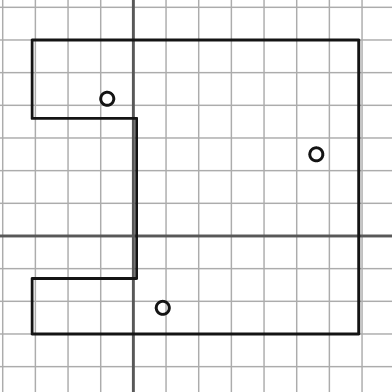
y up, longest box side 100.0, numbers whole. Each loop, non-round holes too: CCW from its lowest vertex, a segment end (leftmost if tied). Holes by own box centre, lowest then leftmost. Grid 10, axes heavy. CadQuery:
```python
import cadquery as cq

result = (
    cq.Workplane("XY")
    .moveTo(-31.0, -30.0)
    .lineTo(69.0, -30.0)
    .lineTo(69.0, 60.0)
    .lineTo(-31.0, 60.0)
    .lineTo(-31.0, 36.0)
    .lineTo(1.0, 36.0)
    .lineTo(1.0, -13.0)
    .lineTo(-31.0, -13.0)
    .close()
    .moveTo(9.0, -22.0)
    .circle(2.0)
    .moveTo(56.0, 25.0)
    .circle(2.0)
    .moveTo(-8.0, 42.0)
    .circle(2.0)
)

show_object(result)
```